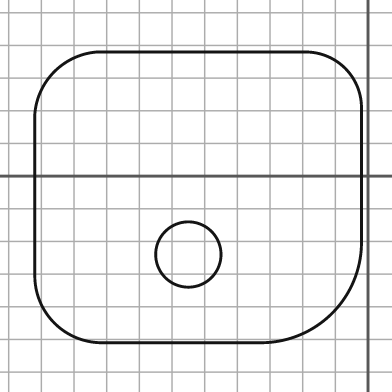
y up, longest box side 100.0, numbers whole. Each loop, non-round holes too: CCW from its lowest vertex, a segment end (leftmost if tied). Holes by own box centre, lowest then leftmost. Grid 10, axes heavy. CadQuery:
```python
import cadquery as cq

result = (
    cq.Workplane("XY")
    .moveTo(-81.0, -51.0)
    .lineTo(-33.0, -51.0)
    .threePointArc((-11.0, -42.0), (-2.0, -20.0))
    .lineTo(-2.0, 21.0)
    .threePointArc((-7.0, 33.0), (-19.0, 38.0))
    .lineTo(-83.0, 38.0)
    .threePointArc((-96.0, 32.0), (-102.0, 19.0))
    .lineTo(-102.0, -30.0)
    .threePointArc((-96.0, -45.0), (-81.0, -51.0))
    .close()
    .moveTo(-55.0, -24.0)
    .circle(10.0)
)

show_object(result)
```